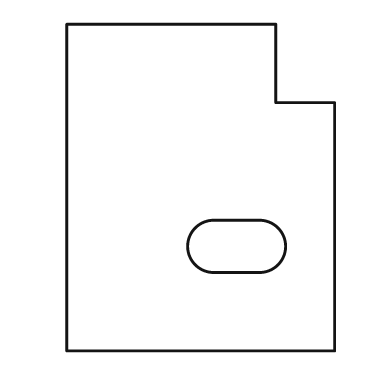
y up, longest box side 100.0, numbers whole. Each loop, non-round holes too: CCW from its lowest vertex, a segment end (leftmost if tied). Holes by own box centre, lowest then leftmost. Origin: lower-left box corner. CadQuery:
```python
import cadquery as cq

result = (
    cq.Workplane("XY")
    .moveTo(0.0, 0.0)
    .lineTo(82.0, 0.0)
    .lineTo(82.0, 76.0)
    .lineTo(64.0, 76.0)
    .lineTo(64.0, 100.0)
    .lineTo(0.0, 100.0)
    .close()
    .moveTo(45.0, 24.0)
    .lineTo(59.0, 24.0)
    .threePointArc((67.0, 32.0), (59.0, 40.0))
    .lineTo(45.0, 40.0)
    .threePointArc((37.0, 32.0), (45.0, 24.0))
    .close()
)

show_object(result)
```